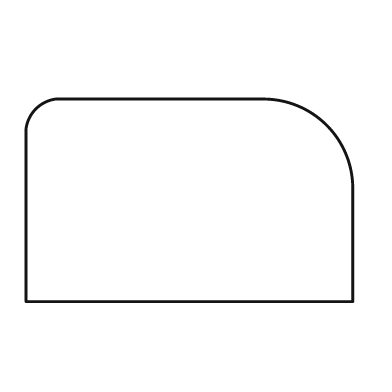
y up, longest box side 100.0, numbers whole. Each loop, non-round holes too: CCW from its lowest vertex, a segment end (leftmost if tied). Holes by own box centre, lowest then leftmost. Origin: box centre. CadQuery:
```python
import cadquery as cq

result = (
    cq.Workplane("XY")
    .moveTo(-50.0, -31.0)
    .lineTo(50.0, -31.0)
    .lineTo(50.0, 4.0)
    .threePointArc((42.0, 23.0), (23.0, 31.0))
    .lineTo(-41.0, 31.0)
    .threePointArc((-47.0, 28.0), (-50.0, 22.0))
    .close()
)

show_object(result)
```